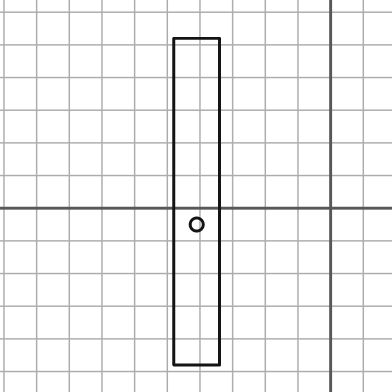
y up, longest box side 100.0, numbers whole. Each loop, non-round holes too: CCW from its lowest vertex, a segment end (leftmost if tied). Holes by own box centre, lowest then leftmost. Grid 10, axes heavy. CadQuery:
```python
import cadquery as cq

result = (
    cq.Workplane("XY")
    .moveTo(-48.0, -48.0)
    .lineTo(-34.0, -48.0)
    .lineTo(-34.0, 52.0)
    .lineTo(-48.0, 52.0)
    .close()
    .moveTo(-41.0, -5.0)
    .circle(2.0)
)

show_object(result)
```